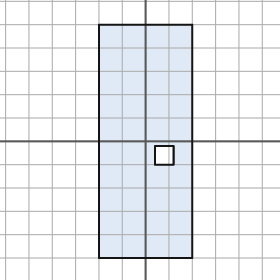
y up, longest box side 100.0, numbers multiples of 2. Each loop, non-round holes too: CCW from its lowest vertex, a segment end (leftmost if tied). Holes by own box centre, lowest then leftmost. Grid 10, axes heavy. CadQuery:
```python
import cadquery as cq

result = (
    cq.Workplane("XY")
    .moveTo(-20.0, -50.0)
    .lineTo(20.0, -50.0)
    .lineTo(20.0, 50.0)
    .lineTo(-20.0, 50.0)
    .close()
    .moveTo(4.0, -10.0)
    .lineTo(12.0, -10.0)
    .lineTo(12.0, -2.0)
    .lineTo(4.0, -2.0)
    .close()
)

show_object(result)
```